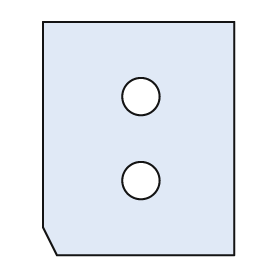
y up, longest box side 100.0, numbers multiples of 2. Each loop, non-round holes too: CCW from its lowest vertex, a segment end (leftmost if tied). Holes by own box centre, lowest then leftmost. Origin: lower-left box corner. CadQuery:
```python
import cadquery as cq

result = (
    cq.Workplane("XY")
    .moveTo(6.0, 0.0)
    .lineTo(82.0, 0.0)
    .lineTo(82.0, 100.0)
    .lineTo(0.0, 100.0)
    .lineTo(0.0, 12.0)
    .close()
    .moveTo(42.0, 32.0)
    .circle(8.0)
    .moveTo(42.0, 68.0)
    .circle(8.0)
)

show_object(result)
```